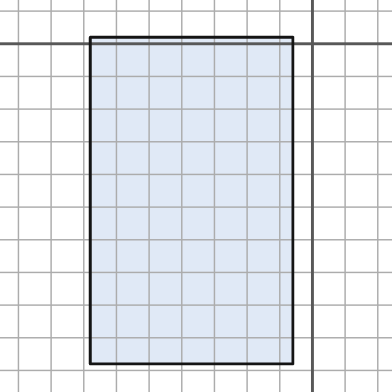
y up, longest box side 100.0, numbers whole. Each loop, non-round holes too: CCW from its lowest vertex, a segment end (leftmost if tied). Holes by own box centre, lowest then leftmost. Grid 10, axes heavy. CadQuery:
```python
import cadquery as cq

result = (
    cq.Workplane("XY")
    .moveTo(-68.0, -98.0)
    .lineTo(-6.0, -98.0)
    .lineTo(-6.0, 2.0)
    .lineTo(-68.0, 2.0)
    .close()
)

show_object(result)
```